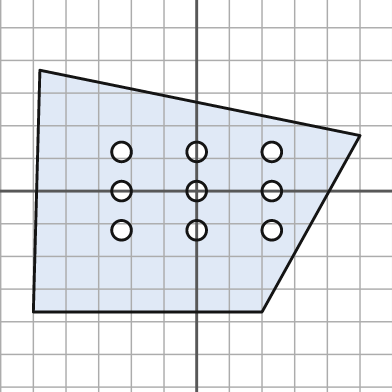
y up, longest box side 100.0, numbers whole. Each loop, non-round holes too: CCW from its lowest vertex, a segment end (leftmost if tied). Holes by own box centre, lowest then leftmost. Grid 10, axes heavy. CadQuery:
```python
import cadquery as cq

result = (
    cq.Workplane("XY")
    .moveTo(-50.0, -37.0)
    .lineTo(20.0, -37.0)
    .lineTo(50.0, 17.0)
    .lineTo(-48.0, 37.0)
    .close()
    .moveTo(-23.0, -12.0)
    .circle(3.0)
    .moveTo(0.0, -12.0)
    .circle(3.0)
    .moveTo(23.0, -12.0)
    .circle(3.0)
    .moveTo(-23.0, 0.0)
    .circle(3.0)
    .moveTo(0.0, 0.0)
    .circle(3.0)
    .moveTo(23.0, 0.0)
    .circle(3.0)
    .moveTo(-23.0, 12.0)
    .circle(3.0)
    .moveTo(0.0, 12.0)
    .circle(3.0)
    .moveTo(23.0, 12.0)
    .circle(3.0)
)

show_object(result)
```